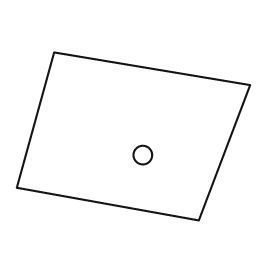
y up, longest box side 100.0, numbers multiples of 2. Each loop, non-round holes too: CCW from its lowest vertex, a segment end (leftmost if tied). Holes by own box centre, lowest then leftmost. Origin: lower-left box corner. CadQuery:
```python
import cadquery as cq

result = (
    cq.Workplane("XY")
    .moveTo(78.0, 0.0)
    .lineTo(100.0, 58.0)
    .lineTo(16.0, 72.0)
    .lineTo(0.0, 14.0)
    .close()
    .moveTo(54.0, 28.0)
    .circle(4.0)
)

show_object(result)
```